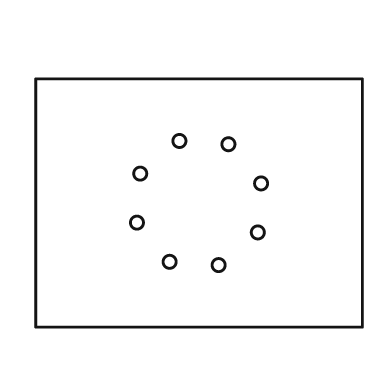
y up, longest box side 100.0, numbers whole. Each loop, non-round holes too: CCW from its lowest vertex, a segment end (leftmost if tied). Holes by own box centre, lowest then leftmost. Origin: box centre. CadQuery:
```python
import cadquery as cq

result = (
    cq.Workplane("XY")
    .moveTo(-50.0, -38.0)
    .lineTo(50.0, -38.0)
    .lineTo(50.0, 38.0)
    .lineTo(-50.0, 38.0)
    .close()
    .moveTo(6.0, -19.0)
    .circle(2.0)
    .moveTo(-9.0, -18.0)
    .circle(2.0)
    .moveTo(18.0, -9.0)
    .circle(2.0)
    .moveTo(-19.0, -6.0)
    .circle(2.0)
    .moveTo(19.0, 6.0)
    .circle(2.0)
    .moveTo(-18.0, 9.0)
    .circle(2.0)
    .moveTo(9.0, 18.0)
    .circle(2.0)
    .moveTo(-6.0, 19.0)
    .circle(2.0)
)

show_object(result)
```